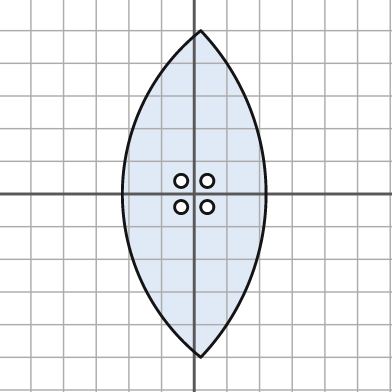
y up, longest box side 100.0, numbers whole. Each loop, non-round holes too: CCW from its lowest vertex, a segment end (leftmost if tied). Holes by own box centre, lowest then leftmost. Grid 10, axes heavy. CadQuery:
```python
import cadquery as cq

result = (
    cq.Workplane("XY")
    .moveTo(2.0, -50.0)
    .threePointArc((22.0, 0.0), (2.0, 50.0))
    .threePointArc((-22.0, 0.0), (2.0, -50.0))
    .close()
    .moveTo(-4.0, -4.0)
    .circle(2.0)
    .moveTo(4.0, -4.0)
    .circle(2.0)
    .moveTo(-4.0, 4.0)
    .circle(2.0)
    .moveTo(4.0, 4.0)
    .circle(2.0)
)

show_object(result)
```